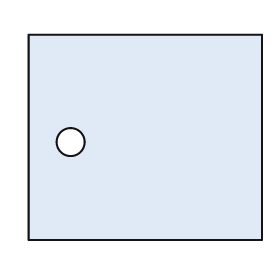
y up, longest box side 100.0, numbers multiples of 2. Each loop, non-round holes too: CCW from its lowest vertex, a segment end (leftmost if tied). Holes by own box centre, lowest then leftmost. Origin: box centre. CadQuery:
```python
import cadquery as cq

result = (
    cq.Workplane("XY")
    .moveTo(-50.0, -44.0)
    .lineTo(50.0, -44.0)
    .lineTo(50.0, 44.0)
    .lineTo(-50.0, 44.0)
    .close()
    .moveTo(-32.0, -2.0)
    .circle(6.0)
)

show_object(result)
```